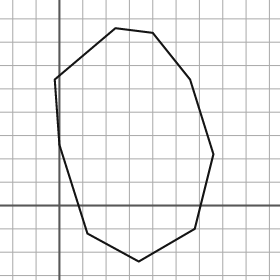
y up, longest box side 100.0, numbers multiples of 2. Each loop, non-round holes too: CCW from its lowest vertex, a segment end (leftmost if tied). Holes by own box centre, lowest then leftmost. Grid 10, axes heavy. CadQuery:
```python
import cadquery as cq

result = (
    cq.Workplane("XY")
    .moveTo(34.0, -24.0)
    .lineTo(58.0, -10.0)
    .lineTo(66.0, 22.0)
    .lineTo(56.0, 54.0)
    .lineTo(40.0, 74.0)
    .lineTo(24.0, 76.0)
    .lineTo(-2.0, 54.0)
    .lineTo(0.0, 26.0)
    .lineTo(12.0, -12.0)
    .close()
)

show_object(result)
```